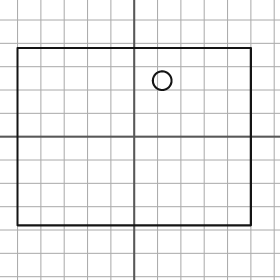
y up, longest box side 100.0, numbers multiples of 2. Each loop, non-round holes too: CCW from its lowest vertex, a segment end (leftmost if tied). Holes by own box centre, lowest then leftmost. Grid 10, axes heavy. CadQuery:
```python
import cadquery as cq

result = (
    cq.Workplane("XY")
    .moveTo(-50.0, -38.0)
    .lineTo(50.0, -38.0)
    .lineTo(50.0, 38.0)
    .lineTo(-50.0, 38.0)
    .close()
    .moveTo(12.0, 24.0)
    .circle(4.0)
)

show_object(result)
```